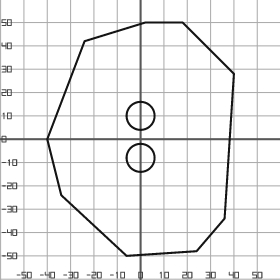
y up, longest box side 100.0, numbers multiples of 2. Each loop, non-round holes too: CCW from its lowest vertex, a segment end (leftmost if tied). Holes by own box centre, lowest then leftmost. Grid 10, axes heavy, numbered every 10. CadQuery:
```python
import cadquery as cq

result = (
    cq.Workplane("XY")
    .moveTo(-6.0, -50.0)
    .lineTo(24.0, -48.0)
    .lineTo(36.0, -34.0)
    .lineTo(40.0, 28.0)
    .lineTo(18.0, 50.0)
    .lineTo(2.0, 50.0)
    .lineTo(-24.0, 42.0)
    .lineTo(-40.0, 0.0)
    .lineTo(-34.0, -24.0)
    .close()
    .moveTo(0.0, -8.0)
    .circle(6.0)
    .moveTo(0.0, 10.0)
    .circle(6.0)
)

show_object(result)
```